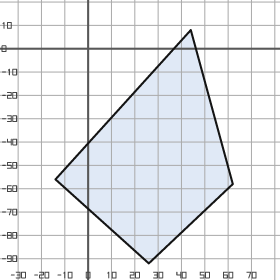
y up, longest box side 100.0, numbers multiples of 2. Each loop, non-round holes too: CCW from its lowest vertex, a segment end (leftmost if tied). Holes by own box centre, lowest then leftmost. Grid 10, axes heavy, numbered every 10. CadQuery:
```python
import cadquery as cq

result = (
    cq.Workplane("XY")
    .moveTo(26.0, -92.0)
    .lineTo(62.0, -58.0)
    .lineTo(44.0, 8.0)
    .lineTo(-14.0, -56.0)
    .close()
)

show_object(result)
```